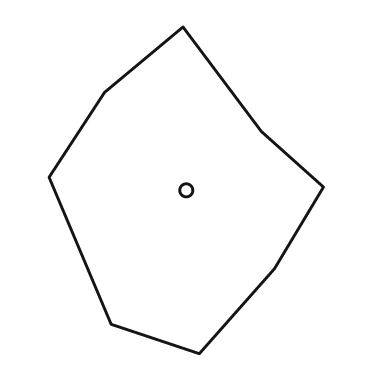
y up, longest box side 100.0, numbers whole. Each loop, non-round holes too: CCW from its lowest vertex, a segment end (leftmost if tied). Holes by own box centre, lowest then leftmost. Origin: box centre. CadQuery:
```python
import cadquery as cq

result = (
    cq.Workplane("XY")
    .moveTo(4.0, -50.0)
    .lineTo(27.0, -24.0)
    .lineTo(42.0, 1.0)
    .lineTo(23.0, 18.0)
    .lineTo(-1.0, 50.0)
    .lineTo(-25.0, 30.0)
    .lineTo(-42.0, 4.0)
    .lineTo(-23.0, -41.0)
    .close()
    .moveTo(0.0, 0.0)
    .circle(2.0)
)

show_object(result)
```